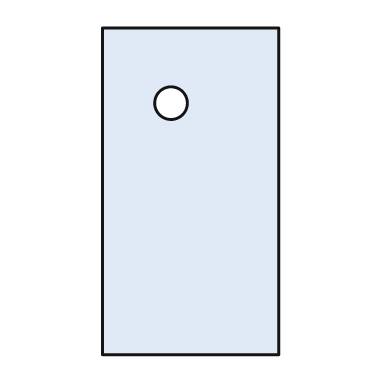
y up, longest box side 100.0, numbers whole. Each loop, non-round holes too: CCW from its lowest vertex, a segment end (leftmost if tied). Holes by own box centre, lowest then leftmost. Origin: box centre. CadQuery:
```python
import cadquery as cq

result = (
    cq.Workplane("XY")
    .moveTo(-27.0, -50.0)
    .lineTo(27.0, -50.0)
    .lineTo(27.0, 50.0)
    .lineTo(-27.0, 50.0)
    .close()
    .moveTo(-6.0, 27.0)
    .circle(5.0)
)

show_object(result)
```